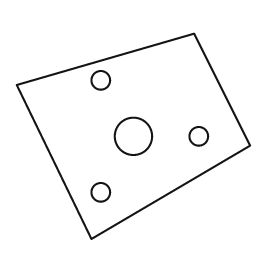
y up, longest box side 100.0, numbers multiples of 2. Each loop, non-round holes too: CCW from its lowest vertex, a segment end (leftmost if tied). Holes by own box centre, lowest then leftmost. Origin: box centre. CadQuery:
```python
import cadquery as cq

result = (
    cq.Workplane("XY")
    .moveTo(-18.0, -44.0)
    .lineTo(50.0, -4.0)
    .lineTo(26.0, 44.0)
    .lineTo(-50.0, 22.0)
    .close()
    .moveTo(-14.0, -24.0)
    .circle(4.0)
    .moveTo(0.0, 0.0)
    .circle(8.0)
    .moveTo(28.0, 0.0)
    .circle(4.0)
    .moveTo(-14.0, 24.0)
    .circle(4.0)
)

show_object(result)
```